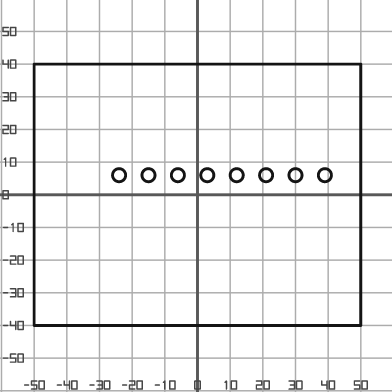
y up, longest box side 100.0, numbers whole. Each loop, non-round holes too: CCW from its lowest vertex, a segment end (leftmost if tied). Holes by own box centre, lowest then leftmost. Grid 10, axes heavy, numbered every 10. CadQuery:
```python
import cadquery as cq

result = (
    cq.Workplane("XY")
    .moveTo(-50.0, -40.0)
    .lineTo(50.0, -40.0)
    .lineTo(50.0, 40.0)
    .lineTo(-50.0, 40.0)
    .close()
    .moveTo(-24.0, 6.0)
    .circle(2.0)
    .moveTo(-15.0, 6.0)
    .circle(2.0)
    .moveTo(-6.0, 6.0)
    .circle(2.0)
    .moveTo(3.0, 6.0)
    .circle(2.0)
    .moveTo(12.0, 6.0)
    .circle(2.0)
    .moveTo(21.0, 6.0)
    .circle(2.0)
    .moveTo(30.0, 6.0)
    .circle(2.0)
    .moveTo(39.0, 6.0)
    .circle(2.0)
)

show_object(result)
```